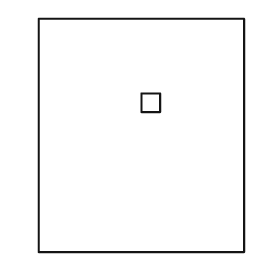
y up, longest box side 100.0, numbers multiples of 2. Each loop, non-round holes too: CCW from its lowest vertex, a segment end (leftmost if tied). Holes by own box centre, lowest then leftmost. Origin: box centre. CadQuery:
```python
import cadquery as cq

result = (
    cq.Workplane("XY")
    .moveTo(-44.0, -50.0)
    .lineTo(44.0, -50.0)
    .lineTo(44.0, 50.0)
    .lineTo(-44.0, 50.0)
    .close()
    .moveTo(0.0, 10.0)
    .lineTo(8.0, 10.0)
    .lineTo(8.0, 18.0)
    .lineTo(0.0, 18.0)
    .close()
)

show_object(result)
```